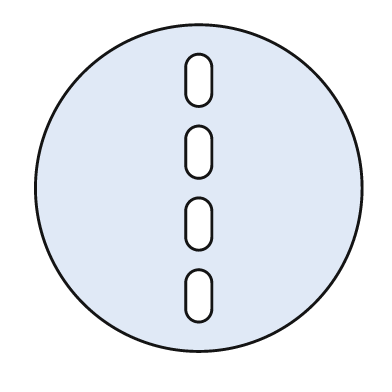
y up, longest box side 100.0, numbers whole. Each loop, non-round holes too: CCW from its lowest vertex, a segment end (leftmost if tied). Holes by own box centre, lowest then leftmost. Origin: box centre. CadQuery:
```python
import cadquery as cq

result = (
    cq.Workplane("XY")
    .moveTo(0.0, 0.0)
    .circle(50.0)
    .moveTo(-4.0, -37.0)
    .threePointArc((0.0, -41.0), (4.0, -37.0))
    .lineTo(4.0, -29.0)
    .threePointArc((0.0, -25.0), (-4.0, -29.0))
    .close()
    .moveTo(-4.0, -15.0)
    .threePointArc((0.0, -19.0), (4.0, -15.0))
    .lineTo(4.0, -7.0)
    .threePointArc((0.0, -3.0), (-4.0, -7.0))
    .close()
    .moveTo(-4.0, 7.0)
    .threePointArc((0.0, 3.0), (4.0, 7.0))
    .lineTo(4.0, 15.0)
    .threePointArc((0.0, 19.0), (-4.0, 15.0))
    .close()
    .moveTo(-4.0, 29.0)
    .threePointArc((0.0, 25.0), (4.0, 29.0))
    .lineTo(4.0, 37.0)
    .threePointArc((0.0, 41.0), (-4.0, 37.0))
    .close()
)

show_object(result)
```